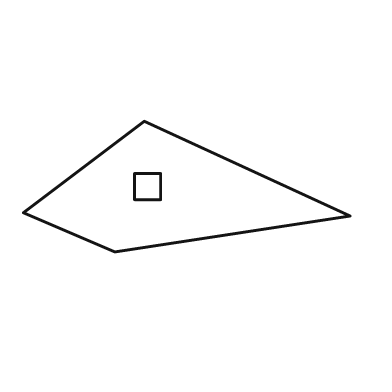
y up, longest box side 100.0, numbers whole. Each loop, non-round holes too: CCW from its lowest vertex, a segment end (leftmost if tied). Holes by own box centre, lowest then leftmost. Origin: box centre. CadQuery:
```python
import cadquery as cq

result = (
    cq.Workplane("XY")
    .moveTo(-22.0, -20.0)
    .lineTo(50.0, -9.0)
    .lineTo(-13.0, 20.0)
    .lineTo(-50.0, -8.0)
    .close()
    .moveTo(-16.0, -4.0)
    .lineTo(-8.0, -4.0)
    .lineTo(-8.0, 4.0)
    .lineTo(-16.0, 4.0)
    .close()
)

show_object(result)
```